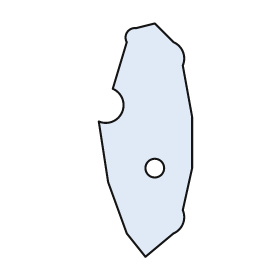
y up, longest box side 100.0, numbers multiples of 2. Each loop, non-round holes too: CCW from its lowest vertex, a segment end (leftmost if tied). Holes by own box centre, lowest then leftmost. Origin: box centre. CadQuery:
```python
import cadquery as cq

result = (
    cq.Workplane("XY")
    .moveTo(0.0, -50.0)
    .lineTo(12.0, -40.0)
    .threePointArc((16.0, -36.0), (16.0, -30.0))
    .lineTo(20.0, -12.0)
    .lineTo(20.0, 10.0)
    .lineTo(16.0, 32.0)
    .threePointArc((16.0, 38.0), (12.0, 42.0))
    .lineTo(4.0, 50.0)
    .lineTo(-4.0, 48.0)
    .threePointArc((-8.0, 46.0), (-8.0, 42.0))
    .lineTo(-14.0, 22.0)
    .threePointArc((-10.0, 12.0), (-20.0, 8.0))
    .lineTo(-16.0, -18.0)
    .lineTo(-8.0, -40.0)
    .close()
    .moveTo(4.0, -12.0)
    .circle(4.0)
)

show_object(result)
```